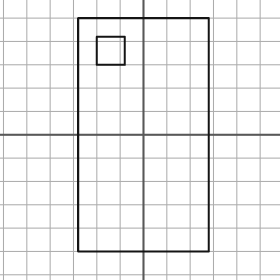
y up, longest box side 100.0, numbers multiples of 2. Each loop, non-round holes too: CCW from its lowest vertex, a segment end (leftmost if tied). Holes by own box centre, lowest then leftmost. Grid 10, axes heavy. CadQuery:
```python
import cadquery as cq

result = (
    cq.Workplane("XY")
    .moveTo(-28.0, -50.0)
    .lineTo(28.0, -50.0)
    .lineTo(28.0, 50.0)
    .lineTo(-28.0, 50.0)
    .close()
    .moveTo(-20.0, 30.0)
    .lineTo(-8.0, 30.0)
    .lineTo(-8.0, 42.0)
    .lineTo(-20.0, 42.0)
    .close()
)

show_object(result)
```